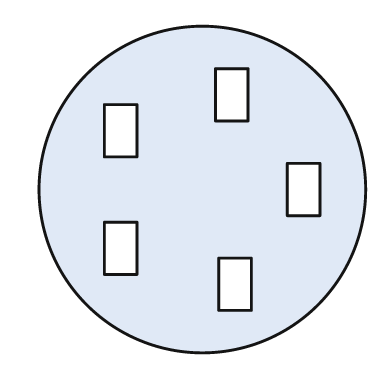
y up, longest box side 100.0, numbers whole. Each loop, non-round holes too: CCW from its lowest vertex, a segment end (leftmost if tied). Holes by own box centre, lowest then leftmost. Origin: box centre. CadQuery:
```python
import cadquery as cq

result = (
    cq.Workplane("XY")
    .moveTo(0.0, 0.0)
    .circle(50.0)
    .moveTo(5.0, -37.0)
    .lineTo(15.0, -37.0)
    .lineTo(15.0, -21.0)
    .lineTo(5.0, -21.0)
    .close()
    .moveTo(-30.0, -26.0)
    .lineTo(-20.0, -26.0)
    .lineTo(-20.0, -10.0)
    .lineTo(-30.0, -10.0)
    .close()
    .moveTo(26.0, -8.0)
    .lineTo(36.0, -8.0)
    .lineTo(36.0, 8.0)
    .lineTo(26.0, 8.0)
    .close()
    .moveTo(-30.0, 10.0)
    .lineTo(-20.0, 10.0)
    .lineTo(-20.0, 26.0)
    .lineTo(-30.0, 26.0)
    .close()
    .moveTo(4.0, 21.0)
    .lineTo(14.0, 21.0)
    .lineTo(14.0, 37.0)
    .lineTo(4.0, 37.0)
    .close()
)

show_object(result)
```